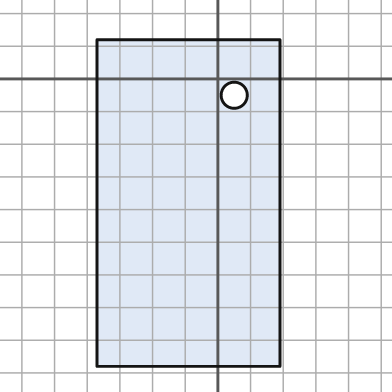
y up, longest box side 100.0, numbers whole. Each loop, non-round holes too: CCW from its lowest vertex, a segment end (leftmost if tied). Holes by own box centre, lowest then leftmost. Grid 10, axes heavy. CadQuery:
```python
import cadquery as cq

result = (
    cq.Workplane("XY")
    .moveTo(-37.0, -88.0)
    .lineTo(19.0, -88.0)
    .lineTo(19.0, 12.0)
    .lineTo(-37.0, 12.0)
    .close()
    .moveTo(5.0, -5.0)
    .circle(4.0)
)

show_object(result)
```